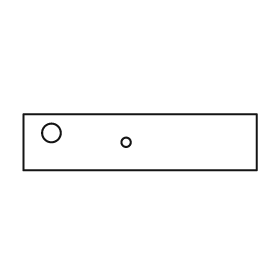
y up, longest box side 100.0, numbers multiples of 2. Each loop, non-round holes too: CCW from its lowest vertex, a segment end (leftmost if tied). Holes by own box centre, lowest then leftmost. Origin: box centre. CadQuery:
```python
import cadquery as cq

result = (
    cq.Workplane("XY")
    .moveTo(-50.0, -12.0)
    .lineTo(50.0, -12.0)
    .lineTo(50.0, 12.0)
    .lineTo(-50.0, 12.0)
    .close()
    .moveTo(-6.0, 0.0)
    .circle(2.0)
    .moveTo(-38.0, 4.0)
    .circle(4.0)
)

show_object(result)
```